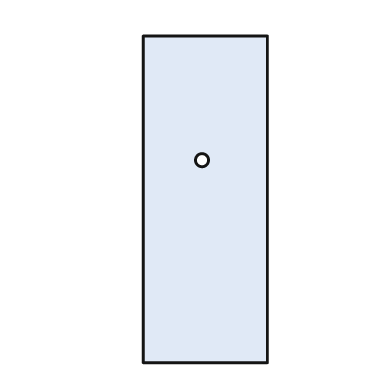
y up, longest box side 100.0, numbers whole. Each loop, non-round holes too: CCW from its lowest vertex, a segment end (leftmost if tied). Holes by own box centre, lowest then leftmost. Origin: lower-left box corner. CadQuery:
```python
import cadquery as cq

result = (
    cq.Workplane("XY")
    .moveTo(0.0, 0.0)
    .lineTo(38.0, 0.0)
    .lineTo(38.0, 100.0)
    .lineTo(0.0, 100.0)
    .close()
    .moveTo(18.0, 62.0)
    .circle(2.0)
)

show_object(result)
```